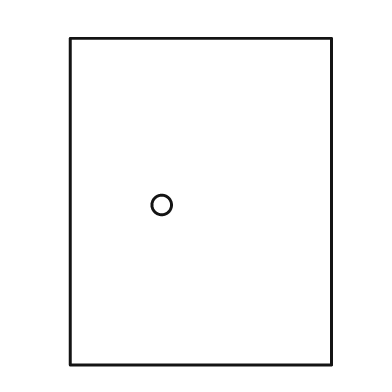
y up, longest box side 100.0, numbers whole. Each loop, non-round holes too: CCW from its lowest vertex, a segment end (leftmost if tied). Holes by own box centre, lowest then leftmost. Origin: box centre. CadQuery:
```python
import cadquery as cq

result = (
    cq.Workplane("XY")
    .moveTo(-40.0, -50.0)
    .lineTo(40.0, -50.0)
    .lineTo(40.0, 50.0)
    .lineTo(-40.0, 50.0)
    .close()
    .moveTo(-12.0, -1.0)
    .circle(3.0)
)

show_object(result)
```